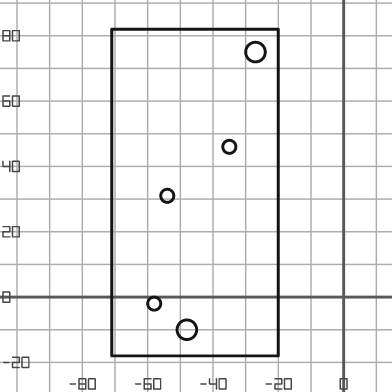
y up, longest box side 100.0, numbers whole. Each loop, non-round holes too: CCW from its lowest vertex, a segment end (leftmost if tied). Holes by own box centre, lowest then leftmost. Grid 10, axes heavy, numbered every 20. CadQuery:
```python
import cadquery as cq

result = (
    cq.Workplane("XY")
    .moveTo(-71.0, -18.0)
    .lineTo(-20.0, -18.0)
    .lineTo(-20.0, 82.0)
    .lineTo(-71.0, 82.0)
    .close()
    .moveTo(-48.0, -10.0)
    .circle(3.0)
    .moveTo(-58.0, -2.0)
    .circle(2.0)
    .moveTo(-54.0, 31.0)
    .circle(2.0)
    .moveTo(-35.0, 46.0)
    .circle(2.0)
    .moveTo(-27.0, 75.0)
    .circle(3.0)
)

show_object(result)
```